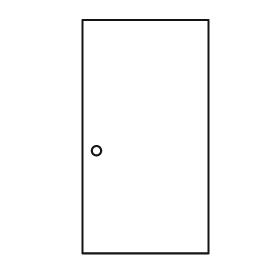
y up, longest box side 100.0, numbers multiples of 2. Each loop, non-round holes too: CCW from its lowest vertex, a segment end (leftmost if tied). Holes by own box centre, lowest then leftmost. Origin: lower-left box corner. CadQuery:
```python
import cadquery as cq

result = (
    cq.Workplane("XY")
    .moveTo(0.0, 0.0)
    .lineTo(54.0, 0.0)
    .lineTo(54.0, 100.0)
    .lineTo(0.0, 100.0)
    .close()
    .moveTo(6.0, 44.0)
    .circle(2.0)
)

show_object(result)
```